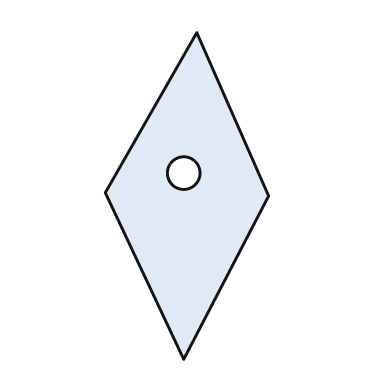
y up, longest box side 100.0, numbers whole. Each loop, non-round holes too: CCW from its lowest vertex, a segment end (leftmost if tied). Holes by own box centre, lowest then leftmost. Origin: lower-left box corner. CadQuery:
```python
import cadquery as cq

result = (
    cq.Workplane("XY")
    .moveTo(24.0, 0.0)
    .lineTo(50.0, 50.0)
    .lineTo(28.0, 100.0)
    .lineTo(0.0, 51.0)
    .close()
    .moveTo(24.0, 57.0)
    .circle(5.0)
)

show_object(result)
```